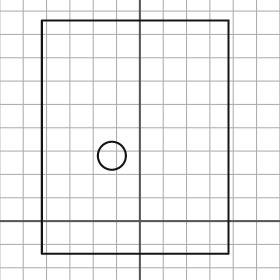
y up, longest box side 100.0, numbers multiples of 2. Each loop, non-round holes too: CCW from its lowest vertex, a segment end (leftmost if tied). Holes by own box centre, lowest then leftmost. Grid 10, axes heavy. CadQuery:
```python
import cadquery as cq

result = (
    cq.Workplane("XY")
    .moveTo(-42.0, -14.0)
    .lineTo(38.0, -14.0)
    .lineTo(38.0, 86.0)
    .lineTo(-42.0, 86.0)
    .close()
    .moveTo(-12.0, 28.0)
    .circle(6.0)
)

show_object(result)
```